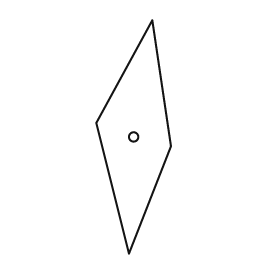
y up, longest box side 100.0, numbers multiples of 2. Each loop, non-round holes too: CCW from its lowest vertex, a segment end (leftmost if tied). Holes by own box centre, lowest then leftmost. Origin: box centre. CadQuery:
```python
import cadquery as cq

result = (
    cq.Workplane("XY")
    .moveTo(-2.0, -50.0)
    .lineTo(16.0, -4.0)
    .lineTo(8.0, 50.0)
    .lineTo(-16.0, 6.0)
    .close()
    .moveTo(0.0, 0.0)
    .circle(2.0)
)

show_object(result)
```